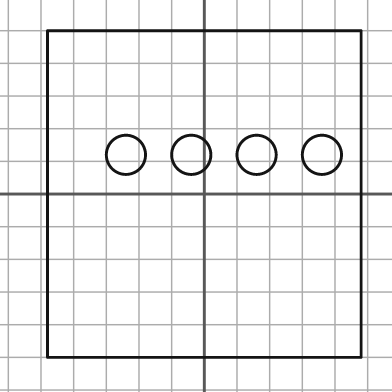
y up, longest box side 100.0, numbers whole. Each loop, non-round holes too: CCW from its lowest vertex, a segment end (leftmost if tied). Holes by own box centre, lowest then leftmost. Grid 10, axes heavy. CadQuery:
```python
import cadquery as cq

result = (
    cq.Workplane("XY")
    .moveTo(-48.0, -50.0)
    .lineTo(48.0, -50.0)
    .lineTo(48.0, 50.0)
    .lineTo(-48.0, 50.0)
    .close()
    .moveTo(-24.0, 12.0)
    .circle(6.0)
    .moveTo(-4.0, 12.0)
    .circle(6.0)
    .moveTo(16.0, 12.0)
    .circle(6.0)
    .moveTo(36.0, 12.0)
    .circle(6.0)
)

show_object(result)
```